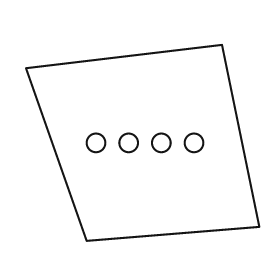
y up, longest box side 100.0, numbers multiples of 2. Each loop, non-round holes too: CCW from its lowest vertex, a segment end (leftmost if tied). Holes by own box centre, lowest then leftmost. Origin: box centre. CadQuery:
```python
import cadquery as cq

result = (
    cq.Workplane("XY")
    .moveTo(-24.0, -42.0)
    .lineTo(50.0, -36.0)
    .lineTo(34.0, 42.0)
    .lineTo(-50.0, 32.0)
    .close()
    .moveTo(-20.0, 0.0)
    .circle(4.0)
    .moveTo(-6.0, 0.0)
    .circle(4.0)
    .moveTo(8.0, 0.0)
    .circle(4.0)
    .moveTo(22.0, 0.0)
    .circle(4.0)
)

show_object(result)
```